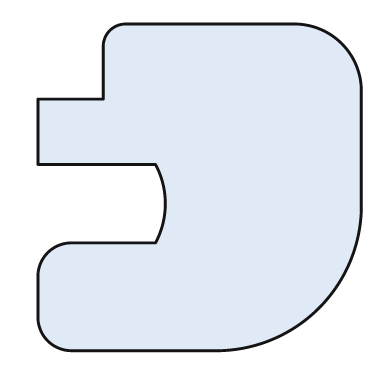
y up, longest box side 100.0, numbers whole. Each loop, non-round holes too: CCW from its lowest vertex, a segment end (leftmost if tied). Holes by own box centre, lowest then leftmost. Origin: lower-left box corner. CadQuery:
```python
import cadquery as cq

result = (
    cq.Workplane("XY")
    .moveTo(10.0, 0.0)
    .lineTo(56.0, 0.0)
    .threePointArc((86.0, 13.0), (99.0, 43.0))
    .lineTo(99.0, 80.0)
    .threePointArc((93.0, 94.0), (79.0, 100.0))
    .lineTo(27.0, 100.0)
    .threePointArc((22.0, 98.0), (20.0, 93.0))
    .lineTo(20.0, 77.0)
    .lineTo(0.0, 77.0)
    .lineTo(0.0, 57.0)
    .lineTo(36.0, 57.0)
    .threePointArc((39.0, 45.0), (36.0, 33.0))
    .lineTo(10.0, 33.0)
    .threePointArc((3.0, 30.0), (0.0, 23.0))
    .lineTo(0.0, 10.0)
    .threePointArc((3.0, 3.0), (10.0, 0.0))
    .close()
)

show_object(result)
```